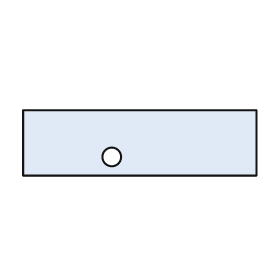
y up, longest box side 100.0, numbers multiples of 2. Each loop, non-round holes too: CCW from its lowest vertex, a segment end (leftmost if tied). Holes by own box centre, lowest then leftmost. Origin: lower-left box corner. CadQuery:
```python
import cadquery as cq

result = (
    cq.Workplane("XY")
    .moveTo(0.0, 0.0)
    .lineTo(100.0, 0.0)
    .lineTo(100.0, 28.0)
    .lineTo(0.0, 28.0)
    .close()
    .moveTo(38.0, 8.0)
    .circle(4.0)
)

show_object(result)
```